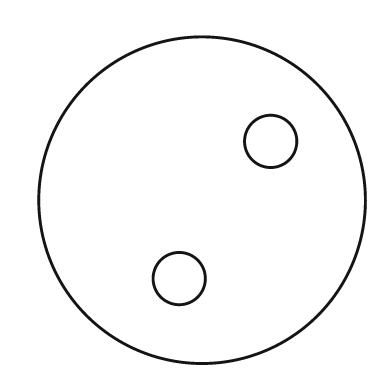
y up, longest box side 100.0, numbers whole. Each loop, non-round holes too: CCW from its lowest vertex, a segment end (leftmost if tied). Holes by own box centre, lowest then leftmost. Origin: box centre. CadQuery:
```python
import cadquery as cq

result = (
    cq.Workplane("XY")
    .moveTo(0.0, 0.0)
    .circle(50.0)
    .moveTo(-7.0, -24.0)
    .circle(8.0)
    .moveTo(21.0, 18.0)
    .circle(8.0)
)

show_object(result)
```